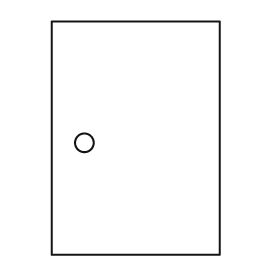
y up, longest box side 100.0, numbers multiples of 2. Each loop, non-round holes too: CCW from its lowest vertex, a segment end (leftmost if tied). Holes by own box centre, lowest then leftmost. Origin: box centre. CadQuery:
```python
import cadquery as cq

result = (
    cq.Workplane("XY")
    .moveTo(-36.0, -50.0)
    .lineTo(36.0, -50.0)
    .lineTo(36.0, 50.0)
    .lineTo(-36.0, 50.0)
    .close()
    .moveTo(-22.0, -2.0)
    .circle(4.0)
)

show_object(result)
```